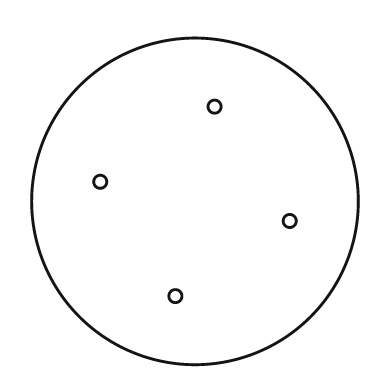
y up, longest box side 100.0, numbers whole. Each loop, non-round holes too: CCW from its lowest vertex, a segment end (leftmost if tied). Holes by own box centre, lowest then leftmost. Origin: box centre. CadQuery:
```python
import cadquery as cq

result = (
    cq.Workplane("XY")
    .moveTo(0.0, 0.0)
    .circle(50.0)
    .moveTo(-6.0, -29.0)
    .circle(2.0)
    .moveTo(29.0, -6.0)
    .circle(2.0)
    .moveTo(-29.0, 6.0)
    .circle(2.0)
    .moveTo(6.0, 29.0)
    .circle(2.0)
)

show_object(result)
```